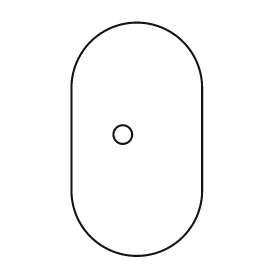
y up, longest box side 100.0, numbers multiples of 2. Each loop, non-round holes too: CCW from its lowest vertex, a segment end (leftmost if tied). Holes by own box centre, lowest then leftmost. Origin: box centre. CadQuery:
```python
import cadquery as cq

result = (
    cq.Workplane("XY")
    .moveTo(-28.0, -22.0)
    .threePointArc((0.0, -50.0), (28.0, -22.0))
    .lineTo(28.0, 22.0)
    .threePointArc((0.0, 50.0), (-28.0, 22.0))
    .close()
    .moveTo(-6.0, 2.0)
    .circle(4.0)
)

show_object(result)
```